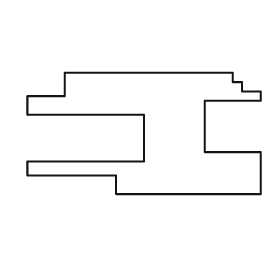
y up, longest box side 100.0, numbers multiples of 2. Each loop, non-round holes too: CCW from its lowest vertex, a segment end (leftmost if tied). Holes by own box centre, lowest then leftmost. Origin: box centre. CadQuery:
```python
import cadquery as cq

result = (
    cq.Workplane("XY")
    .moveTo(-12.0, -26.0)
    .lineTo(50.0, -26.0)
    .lineTo(50.0, -8.0)
    .lineTo(26.0, -8.0)
    .lineTo(26.0, 14.0)
    .lineTo(50.0, 14.0)
    .lineTo(50.0, 18.0)
    .lineTo(42.0, 18.0)
    .lineTo(42.0, 22.0)
    .lineTo(38.0, 22.0)
    .lineTo(38.0, 26.0)
    .lineTo(-34.0, 26.0)
    .lineTo(-34.0, 16.0)
    .lineTo(-50.0, 16.0)
    .lineTo(-50.0, 8.0)
    .lineTo(0.0, 8.0)
    .lineTo(0.0, -12.0)
    .lineTo(-50.0, -12.0)
    .lineTo(-50.0, -18.0)
    .lineTo(-12.0, -18.0)
    .close()
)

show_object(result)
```